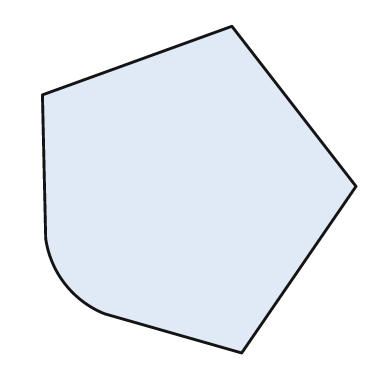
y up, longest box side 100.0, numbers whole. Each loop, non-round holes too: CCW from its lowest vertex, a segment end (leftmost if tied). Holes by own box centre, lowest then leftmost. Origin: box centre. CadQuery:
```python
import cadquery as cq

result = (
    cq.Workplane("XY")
    .moveTo(13.0, -50.0)
    .lineTo(48.0, 1.0)
    .lineTo(10.0, 50.0)
    .lineTo(-48.0, 29.0)
    .lineTo(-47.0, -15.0)
    .threePointArc((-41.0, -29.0), (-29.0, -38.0))
    .close()
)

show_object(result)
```